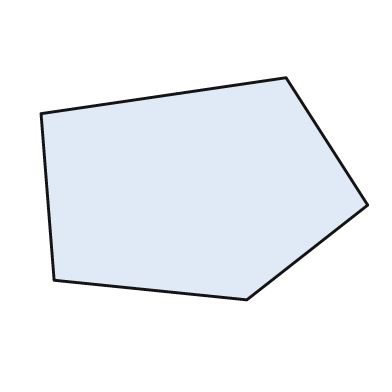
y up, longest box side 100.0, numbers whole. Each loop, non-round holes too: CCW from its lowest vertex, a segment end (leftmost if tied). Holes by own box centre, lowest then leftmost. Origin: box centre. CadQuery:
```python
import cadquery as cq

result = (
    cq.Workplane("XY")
    .moveTo(13.0, -34.0)
    .lineTo(50.0, -5.0)
    .lineTo(25.0, 34.0)
    .lineTo(-50.0, 23.0)
    .lineTo(-46.0, -28.0)
    .close()
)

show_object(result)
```